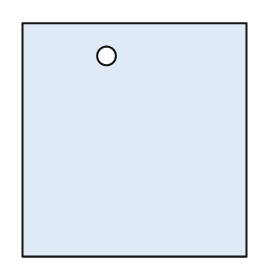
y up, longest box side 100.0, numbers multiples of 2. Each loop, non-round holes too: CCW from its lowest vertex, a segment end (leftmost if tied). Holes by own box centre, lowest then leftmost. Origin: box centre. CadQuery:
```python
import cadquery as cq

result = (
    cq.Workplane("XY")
    .moveTo(-48.0, -50.0)
    .lineTo(48.0, -50.0)
    .lineTo(48.0, 50.0)
    .lineTo(-48.0, 50.0)
    .close()
    .moveTo(-12.0, 36.0)
    .circle(4.0)
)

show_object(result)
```